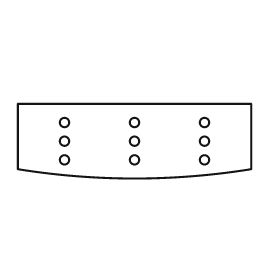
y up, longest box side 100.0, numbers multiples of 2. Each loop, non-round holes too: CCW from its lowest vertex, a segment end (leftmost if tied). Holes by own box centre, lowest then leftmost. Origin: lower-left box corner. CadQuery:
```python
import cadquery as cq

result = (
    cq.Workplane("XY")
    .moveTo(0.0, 4.0)
    .threePointArc((50.0, 0.0), (100.0, 4.0))
    .lineTo(100.0, 32.0)
    .lineTo(0.0, 32.0)
    .close()
    .moveTo(20.0, 8.0)
    .circle(2.0)
    .moveTo(50.0, 8.0)
    .circle(2.0)
    .moveTo(80.0, 8.0)
    .circle(2.0)
    .moveTo(20.0, 16.0)
    .circle(2.0)
    .moveTo(50.0, 16.0)
    .circle(2.0)
    .moveTo(80.0, 16.0)
    .circle(2.0)
    .moveTo(20.0, 24.0)
    .circle(2.0)
    .moveTo(50.0, 24.0)
    .circle(2.0)
    .moveTo(80.0, 24.0)
    .circle(2.0)
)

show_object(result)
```